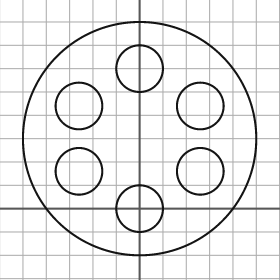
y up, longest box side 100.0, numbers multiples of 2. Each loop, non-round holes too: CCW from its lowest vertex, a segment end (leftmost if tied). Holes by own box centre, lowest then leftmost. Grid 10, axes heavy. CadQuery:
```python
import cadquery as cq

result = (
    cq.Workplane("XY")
    .moveTo(0.0, 30.0)
    .circle(50.0)
    .moveTo(0.0, 0.0)
    .circle(10.0)
    .moveTo(-26.0, 16.0)
    .circle(10.0)
    .moveTo(26.0, 16.0)
    .circle(10.0)
    .moveTo(-26.0, 44.0)
    .circle(10.0)
    .moveTo(26.0, 44.0)
    .circle(10.0)
    .moveTo(0.0, 60.0)
    .circle(10.0)
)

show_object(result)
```